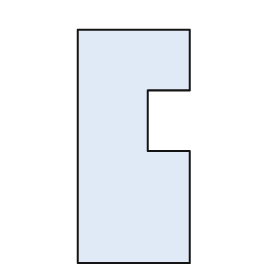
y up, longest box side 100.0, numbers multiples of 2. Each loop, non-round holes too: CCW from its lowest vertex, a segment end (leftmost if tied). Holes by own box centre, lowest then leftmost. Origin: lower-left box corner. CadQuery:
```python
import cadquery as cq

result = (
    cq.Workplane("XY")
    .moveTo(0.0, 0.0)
    .lineTo(48.0, 0.0)
    .lineTo(48.0, 48.0)
    .lineTo(30.0, 48.0)
    .lineTo(30.0, 74.0)
    .lineTo(48.0, 74.0)
    .lineTo(48.0, 100.0)
    .lineTo(0.0, 100.0)
    .close()
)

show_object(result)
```